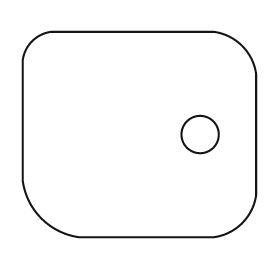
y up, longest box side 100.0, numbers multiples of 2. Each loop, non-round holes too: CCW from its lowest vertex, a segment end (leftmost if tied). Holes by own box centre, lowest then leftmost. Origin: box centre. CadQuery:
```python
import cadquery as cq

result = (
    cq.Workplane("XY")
    .moveTo(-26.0, -44.0)
    .lineTo(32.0, -44.0)
    .threePointArc((44.0, -38.0), (50.0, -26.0))
    .lineTo(50.0, 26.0)
    .threePointArc((44.0, 38.0), (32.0, 44.0))
    .lineTo(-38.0, 44.0)
    .threePointArc((-46.0, 40.0), (-50.0, 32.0))
    .lineTo(-50.0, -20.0)
    .threePointArc((-42.0, -36.0), (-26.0, -44.0))
    .close()
    .moveTo(26.0, 0.0)
    .circle(8.0)
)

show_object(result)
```